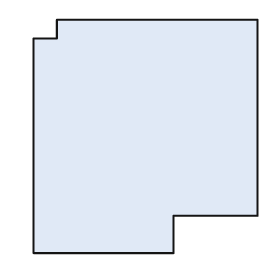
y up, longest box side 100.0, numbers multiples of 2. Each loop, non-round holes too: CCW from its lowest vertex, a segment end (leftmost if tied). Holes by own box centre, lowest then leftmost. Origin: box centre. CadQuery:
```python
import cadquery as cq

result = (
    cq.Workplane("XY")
    .moveTo(-48.0, -50.0)
    .lineTo(12.0, -50.0)
    .lineTo(12.0, -34.0)
    .lineTo(48.0, -34.0)
    .lineTo(48.0, 50.0)
    .lineTo(-38.0, 50.0)
    .lineTo(-38.0, 42.0)
    .lineTo(-48.0, 42.0)
    .close()
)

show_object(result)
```